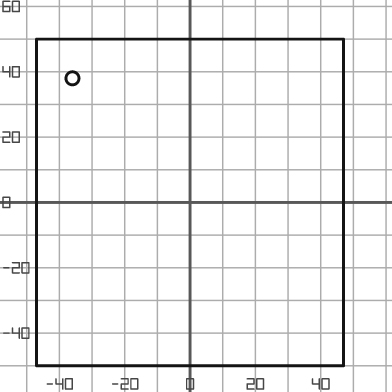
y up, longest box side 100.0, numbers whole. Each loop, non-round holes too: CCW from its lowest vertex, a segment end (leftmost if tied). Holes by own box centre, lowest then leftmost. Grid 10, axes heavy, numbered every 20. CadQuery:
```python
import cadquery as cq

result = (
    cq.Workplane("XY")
    .moveTo(-47.0, -50.0)
    .lineTo(47.0, -50.0)
    .lineTo(47.0, 50.0)
    .lineTo(-47.0, 50.0)
    .close()
    .moveTo(-36.0, 38.0)
    .circle(2.0)
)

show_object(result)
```